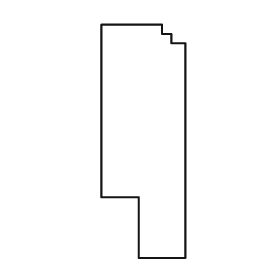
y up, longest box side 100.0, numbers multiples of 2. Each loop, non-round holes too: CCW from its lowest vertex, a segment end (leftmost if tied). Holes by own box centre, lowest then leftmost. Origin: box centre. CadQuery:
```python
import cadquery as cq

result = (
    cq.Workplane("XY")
    .moveTo(-2.0, -50.0)
    .lineTo(18.0, -50.0)
    .lineTo(18.0, 42.0)
    .lineTo(12.0, 42.0)
    .lineTo(12.0, 46.0)
    .lineTo(8.0, 46.0)
    .lineTo(8.0, 50.0)
    .lineTo(-18.0, 50.0)
    .lineTo(-18.0, -24.0)
    .lineTo(-2.0, -24.0)
    .close()
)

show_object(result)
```